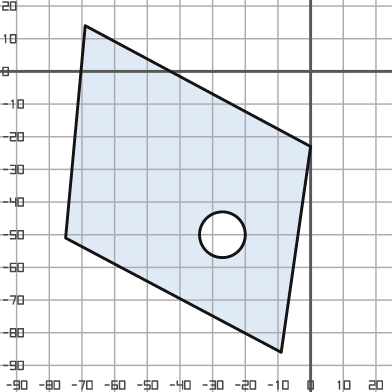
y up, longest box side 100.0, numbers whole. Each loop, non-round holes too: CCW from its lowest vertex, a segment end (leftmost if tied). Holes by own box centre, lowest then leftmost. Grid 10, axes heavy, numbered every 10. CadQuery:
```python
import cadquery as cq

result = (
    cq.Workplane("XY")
    .moveTo(-9.0, -86.0)
    .lineTo(0.0, -23.0)
    .lineTo(-69.0, 14.0)
    .lineTo(-75.0, -51.0)
    .close()
    .moveTo(-27.0, -50.0)
    .circle(7.0)
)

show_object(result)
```